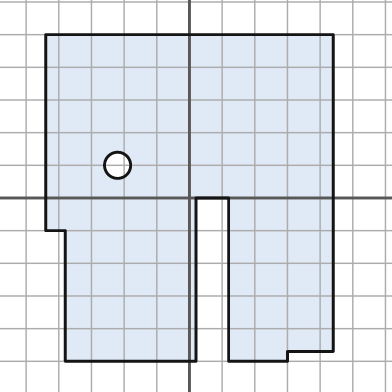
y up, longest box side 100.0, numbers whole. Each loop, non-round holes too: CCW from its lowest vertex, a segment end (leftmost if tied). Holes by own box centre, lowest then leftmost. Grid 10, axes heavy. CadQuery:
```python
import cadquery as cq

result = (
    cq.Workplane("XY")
    .moveTo(-38.0, -50.0)
    .lineTo(2.0, -50.0)
    .lineTo(2.0, 0.0)
    .lineTo(12.0, 0.0)
    .lineTo(12.0, -50.0)
    .lineTo(30.0, -50.0)
    .lineTo(30.0, -47.0)
    .lineTo(44.0, -47.0)
    .lineTo(44.0, 50.0)
    .lineTo(-44.0, 50.0)
    .lineTo(-44.0, -10.0)
    .lineTo(-38.0, -10.0)
    .close()
    .moveTo(-22.0, 10.0)
    .circle(4.0)
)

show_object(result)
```